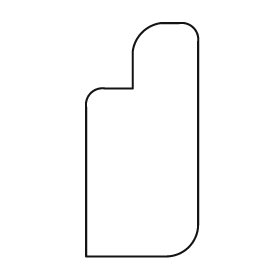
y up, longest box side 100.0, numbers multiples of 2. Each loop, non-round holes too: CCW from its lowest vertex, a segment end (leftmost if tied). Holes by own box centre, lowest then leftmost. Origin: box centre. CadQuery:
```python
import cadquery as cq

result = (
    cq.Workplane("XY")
    .moveTo(-24.0, -50.0)
    .lineTo(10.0, -50.0)
    .threePointArc((20.0, -46.0), (24.0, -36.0))
    .lineTo(24.0, 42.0)
    .threePointArc((22.0, 48.0), (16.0, 50.0))
    .lineTo(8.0, 50.0)
    .threePointArc((0.0, 46.0), (-4.0, 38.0))
    .lineTo(-4.0, 22.0)
    .lineTo(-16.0, 22.0)
    .threePointArc((-22.0, 20.0), (-24.0, 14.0))
    .close()
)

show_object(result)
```